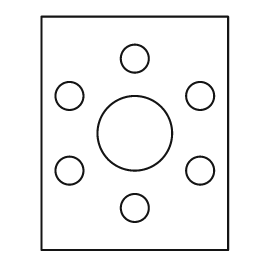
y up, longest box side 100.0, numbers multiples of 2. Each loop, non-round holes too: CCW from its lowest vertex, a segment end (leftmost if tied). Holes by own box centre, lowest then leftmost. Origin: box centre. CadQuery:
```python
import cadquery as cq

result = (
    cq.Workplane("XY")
    .moveTo(-40.0, -50.0)
    .lineTo(40.0, -50.0)
    .lineTo(40.0, 50.0)
    .lineTo(-40.0, 50.0)
    .close()
    .moveTo(0.0, -32.0)
    .circle(6.0)
    .moveTo(-28.0, -16.0)
    .circle(6.0)
    .moveTo(28.0, -16.0)
    .circle(6.0)
    .moveTo(0.0, 0.0)
    .circle(16.0)
    .moveTo(-28.0, 16.0)
    .circle(6.0)
    .moveTo(28.0, 16.0)
    .circle(6.0)
    .moveTo(0.0, 32.0)
    .circle(6.0)
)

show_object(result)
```